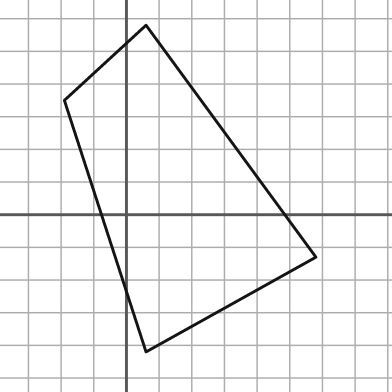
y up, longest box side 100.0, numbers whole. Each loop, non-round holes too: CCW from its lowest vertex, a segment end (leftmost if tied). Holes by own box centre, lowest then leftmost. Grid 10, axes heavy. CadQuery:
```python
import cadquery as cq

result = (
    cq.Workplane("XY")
    .moveTo(6.0, -42.0)
    .lineTo(58.0, -13.0)
    .lineTo(6.0, 58.0)
    .lineTo(-19.0, 35.0)
    .close()
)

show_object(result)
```